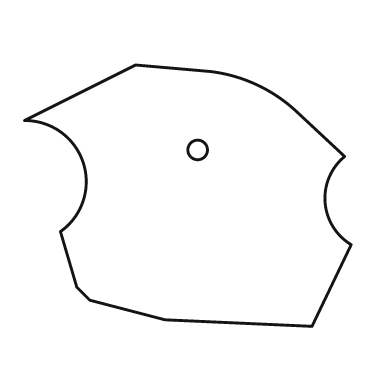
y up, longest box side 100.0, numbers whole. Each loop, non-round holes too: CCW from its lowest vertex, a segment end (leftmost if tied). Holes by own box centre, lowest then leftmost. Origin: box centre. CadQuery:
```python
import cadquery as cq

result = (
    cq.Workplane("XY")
    .moveTo(38.0, -40.0)
    .lineTo(50.0, -15.0)
    .threePointArc((42.0, -2.0), (48.0, 12.0))
    .lineTo(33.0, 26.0)
    .threePointArc((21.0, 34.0), (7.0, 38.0))
    .lineTo(-16.0, 40.0)
    .lineTo(-50.0, 23.0)
    .threePointArc((-32.0, 10.0), (-39.0, -11.0))
    .lineTo(-34.0, -28.0)
    .lineTo(-30.0, -32.0)
    .lineTo(-7.0, -38.0)
    .close()
    .moveTo(3.0, 14.0)
    .circle(3.0)
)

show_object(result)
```